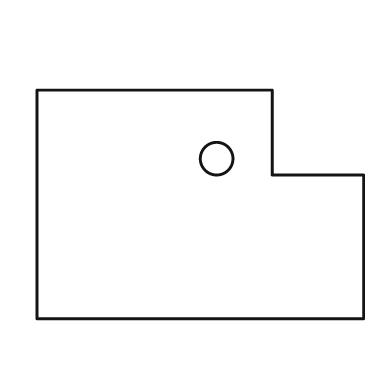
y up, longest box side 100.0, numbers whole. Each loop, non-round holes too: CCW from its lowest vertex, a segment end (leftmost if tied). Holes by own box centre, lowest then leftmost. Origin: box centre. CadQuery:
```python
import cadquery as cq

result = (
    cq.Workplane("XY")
    .moveTo(-50.0, -35.0)
    .lineTo(50.0, -35.0)
    .lineTo(50.0, 9.0)
    .lineTo(22.0, 9.0)
    .lineTo(22.0, 35.0)
    .lineTo(-50.0, 35.0)
    .close()
    .moveTo(5.0, 14.0)
    .circle(5.0)
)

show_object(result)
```